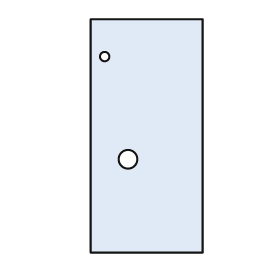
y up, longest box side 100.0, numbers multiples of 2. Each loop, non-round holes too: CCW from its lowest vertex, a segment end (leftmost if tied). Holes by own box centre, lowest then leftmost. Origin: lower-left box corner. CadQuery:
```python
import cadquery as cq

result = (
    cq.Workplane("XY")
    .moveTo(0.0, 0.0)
    .lineTo(48.0, 0.0)
    .lineTo(48.0, 100.0)
    .lineTo(0.0, 100.0)
    .close()
    .moveTo(16.0, 40.0)
    .circle(4.0)
    .moveTo(6.0, 84.0)
    .circle(2.0)
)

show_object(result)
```